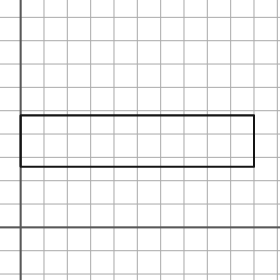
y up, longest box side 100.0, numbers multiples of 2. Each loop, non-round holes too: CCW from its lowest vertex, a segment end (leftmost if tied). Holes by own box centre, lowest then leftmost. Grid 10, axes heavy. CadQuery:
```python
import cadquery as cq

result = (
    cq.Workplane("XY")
    .moveTo(0.0, 26.0)
    .lineTo(100.0, 26.0)
    .lineTo(100.0, 48.0)
    .lineTo(0.0, 48.0)
    .close()
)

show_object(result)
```